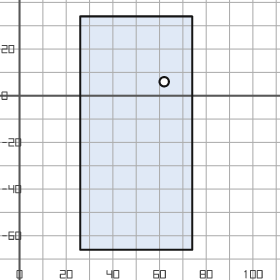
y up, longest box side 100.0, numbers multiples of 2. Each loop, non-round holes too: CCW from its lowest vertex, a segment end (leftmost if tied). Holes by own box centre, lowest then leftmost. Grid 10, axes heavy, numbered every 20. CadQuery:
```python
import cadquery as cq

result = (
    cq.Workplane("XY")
    .moveTo(26.0, -66.0)
    .lineTo(74.0, -66.0)
    .lineTo(74.0, 34.0)
    .lineTo(26.0, 34.0)
    .close()
    .moveTo(62.0, 6.0)
    .circle(2.0)
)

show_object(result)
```